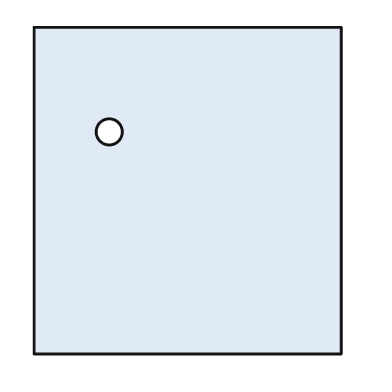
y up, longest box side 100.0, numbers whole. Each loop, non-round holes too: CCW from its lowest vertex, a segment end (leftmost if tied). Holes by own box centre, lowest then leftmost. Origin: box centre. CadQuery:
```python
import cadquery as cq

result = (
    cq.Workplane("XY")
    .moveTo(-47.0, -50.0)
    .lineTo(47.0, -50.0)
    .lineTo(47.0, 50.0)
    .lineTo(-47.0, 50.0)
    .close()
    .moveTo(-24.0, 18.0)
    .circle(4.0)
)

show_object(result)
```